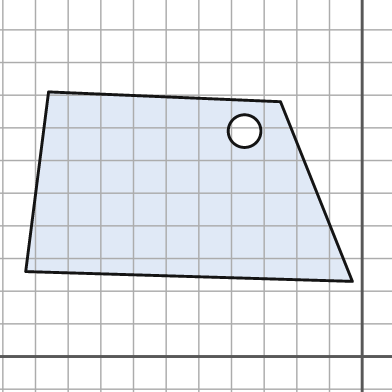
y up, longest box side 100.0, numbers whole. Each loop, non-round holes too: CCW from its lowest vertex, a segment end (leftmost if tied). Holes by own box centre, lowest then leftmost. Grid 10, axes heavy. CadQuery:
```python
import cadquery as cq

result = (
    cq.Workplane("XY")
    .moveTo(-3.0, 23.0)
    .lineTo(-25.0, 78.0)
    .lineTo(-96.0, 81.0)
    .lineTo(-103.0, 26.0)
    .close()
    .moveTo(-36.0, 69.0)
    .circle(5.0)
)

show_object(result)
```